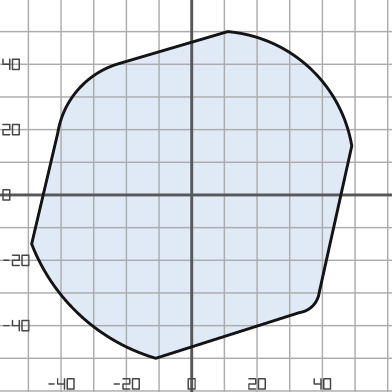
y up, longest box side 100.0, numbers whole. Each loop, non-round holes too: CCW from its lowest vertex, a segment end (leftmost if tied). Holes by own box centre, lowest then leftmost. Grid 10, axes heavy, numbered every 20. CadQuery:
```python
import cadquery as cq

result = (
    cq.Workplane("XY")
    .moveTo(-11.0, -50.0)
    .lineTo(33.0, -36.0)
    .threePointArc((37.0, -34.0), (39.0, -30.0))
    .lineTo(49.0, 15.0)
    .threePointArc((36.0, 39.0), (11.0, 50.0))
    .lineTo(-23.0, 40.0)
    .threePointArc((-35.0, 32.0), (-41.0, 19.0))
    .lineTo(-49.0, -15.0)
    .threePointArc((-34.0, -37.0), (-11.0, -50.0))
    .close()
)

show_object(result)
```